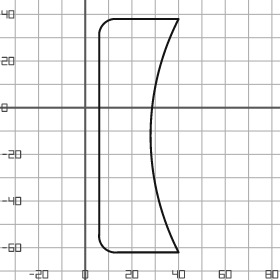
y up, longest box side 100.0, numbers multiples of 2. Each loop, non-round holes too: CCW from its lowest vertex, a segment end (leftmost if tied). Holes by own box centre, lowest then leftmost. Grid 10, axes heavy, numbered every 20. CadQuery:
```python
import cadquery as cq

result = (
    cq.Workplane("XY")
    .moveTo(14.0, -62.0)
    .lineTo(40.0, -62.0)
    .threePointArc((28.0, -12.0), (40.0, 38.0))
    .lineTo(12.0, 38.0)
    .threePointArc((8.0, 36.0), (6.0, 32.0))
    .lineTo(6.0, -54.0)
    .threePointArc((8.0, -60.0), (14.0, -62.0))
    .close()
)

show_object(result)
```